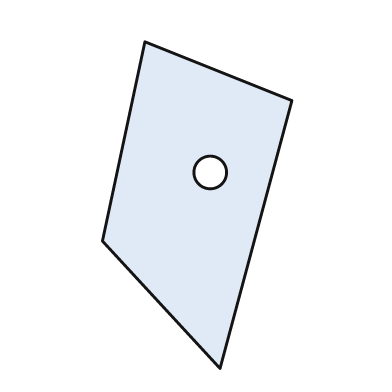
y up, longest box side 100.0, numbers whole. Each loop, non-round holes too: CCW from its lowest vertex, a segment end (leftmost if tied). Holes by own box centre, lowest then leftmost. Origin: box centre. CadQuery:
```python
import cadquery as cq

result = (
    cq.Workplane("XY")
    .moveTo(7.0, -50.0)
    .lineTo(29.0, 32.0)
    .lineTo(-16.0, 50.0)
    .lineTo(-29.0, -11.0)
    .close()
    .moveTo(4.0, 10.0)
    .circle(5.0)
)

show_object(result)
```